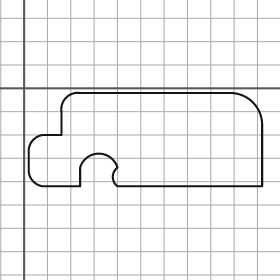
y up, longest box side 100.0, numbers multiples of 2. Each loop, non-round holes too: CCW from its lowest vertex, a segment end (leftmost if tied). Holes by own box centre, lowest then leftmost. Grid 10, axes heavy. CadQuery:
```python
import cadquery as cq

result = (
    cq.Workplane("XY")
    .moveTo(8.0, -42.0)
    .lineTo(24.0, -42.0)
    .lineTo(24.0, -34.0)
    .threePointArc((32.0, -28.0), (40.0, -34.0))
    .threePointArc((38.0, -38.0), (40.0, -42.0))
    .lineTo(102.0, -42.0)
    .lineTo(102.0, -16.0)
    .threePointArc((98.0, -6.0), (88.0, -2.0))
    .lineTo(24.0, -2.0)
    .threePointArc((18.0, -4.0), (16.0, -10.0))
    .lineTo(16.0, -20.0)
    .lineTo(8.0, -20.0)
    .threePointArc((4.0, -22.0), (2.0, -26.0))
    .lineTo(2.0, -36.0)
    .threePointArc((4.0, -40.0), (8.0, -42.0))
    .close()
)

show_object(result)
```